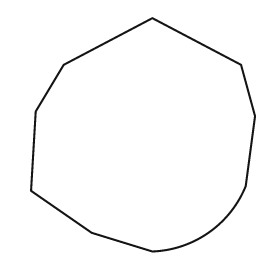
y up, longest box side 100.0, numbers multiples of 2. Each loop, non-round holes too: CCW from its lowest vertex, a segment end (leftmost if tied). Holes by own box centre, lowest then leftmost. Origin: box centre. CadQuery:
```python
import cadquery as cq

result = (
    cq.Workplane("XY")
    .moveTo(4.0, -50.0)
    .threePointArc((28.0, -42.0), (44.0, -22.0))
    .lineTo(48.0, 8.0)
    .lineTo(42.0, 30.0)
    .lineTo(4.0, 50.0)
    .lineTo(-34.0, 30.0)
    .lineTo(-46.0, 10.0)
    .lineTo(-48.0, -24.0)
    .lineTo(-22.0, -42.0)
    .close()
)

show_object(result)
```